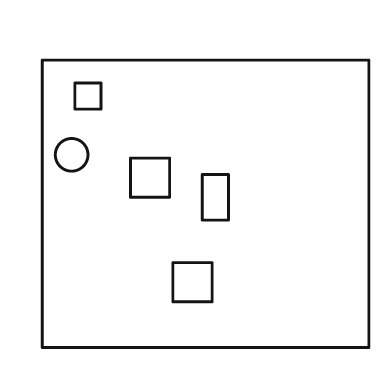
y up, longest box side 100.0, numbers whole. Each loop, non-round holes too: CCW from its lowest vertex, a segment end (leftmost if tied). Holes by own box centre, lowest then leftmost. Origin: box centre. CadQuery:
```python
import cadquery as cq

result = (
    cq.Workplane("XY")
    .moveTo(-50.0, -44.0)
    .lineTo(50.0, -44.0)
    .lineTo(50.0, 44.0)
    .lineTo(-50.0, 44.0)
    .close()
    .moveTo(-10.0, -30.0)
    .lineTo(2.0, -30.0)
    .lineTo(2.0, -18.0)
    .lineTo(-10.0, -18.0)
    .close()
    .moveTo(-1.0, -5.0)
    .lineTo(7.0, -5.0)
    .lineTo(7.0, 9.0)
    .lineTo(-1.0, 9.0)
    .close()
    .moveTo(-23.0, 2.0)
    .lineTo(-11.0, 2.0)
    .lineTo(-11.0, 14.0)
    .lineTo(-23.0, 14.0)
    .close()
    .moveTo(-41.0, 15.0)
    .circle(5.0)
    .moveTo(-40.0, 29.0)
    .lineTo(-32.0, 29.0)
    .lineTo(-32.0, 37.0)
    .lineTo(-40.0, 37.0)
    .close()
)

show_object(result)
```